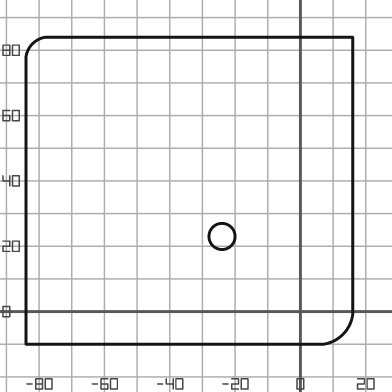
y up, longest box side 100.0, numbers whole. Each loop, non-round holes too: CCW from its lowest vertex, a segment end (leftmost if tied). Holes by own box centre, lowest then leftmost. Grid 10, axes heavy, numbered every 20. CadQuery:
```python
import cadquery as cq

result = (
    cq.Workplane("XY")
    .moveTo(-84.0, -10.0)
    .lineTo(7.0, -10.0)
    .threePointArc((13.0, -7.0), (16.0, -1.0))
    .lineTo(16.0, 84.0)
    .lineTo(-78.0, 84.0)
    .threePointArc((-82.0, 82.0), (-84.0, 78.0))
    .close()
    .moveTo(-24.0, 23.0)
    .circle(4.0)
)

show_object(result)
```